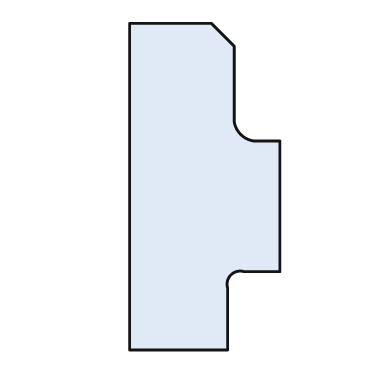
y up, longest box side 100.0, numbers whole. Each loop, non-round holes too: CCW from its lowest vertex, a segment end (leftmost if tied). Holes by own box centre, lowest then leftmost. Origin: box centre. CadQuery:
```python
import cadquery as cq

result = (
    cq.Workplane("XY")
    .moveTo(-23.0, -50.0)
    .lineTo(7.0, -50.0)
    .lineTo(7.0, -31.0)
    .threePointArc((8.0, -27.0), (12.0, -26.0))
    .lineTo(23.0, -26.0)
    .lineTo(23.0, 14.0)
    .lineTo(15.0, 14.0)
    .threePointArc((11.0, 16.0), (9.0, 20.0))
    .lineTo(9.0, 43.0)
    .lineTo(2.0, 50.0)
    .lineTo(-23.0, 50.0)
    .close()
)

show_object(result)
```